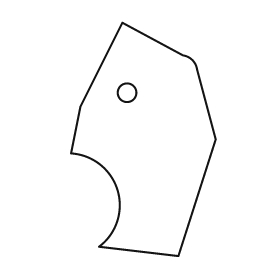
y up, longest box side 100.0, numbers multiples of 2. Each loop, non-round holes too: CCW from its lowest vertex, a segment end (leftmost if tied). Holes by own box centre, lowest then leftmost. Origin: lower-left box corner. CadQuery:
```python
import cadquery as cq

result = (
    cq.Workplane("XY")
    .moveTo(46.0, 0.0)
    .lineTo(62.0, 50.0)
    .lineTo(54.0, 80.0)
    .threePointArc((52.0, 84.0), (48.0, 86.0))
    .lineTo(22.0, 100.0)
    .lineTo(4.0, 64.0)
    .lineTo(0.0, 44.0)
    .threePointArc((20.0, 28.0), (12.0, 4.0))
    .close()
    .moveTo(24.0, 70.0)
    .circle(4.0)
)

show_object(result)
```